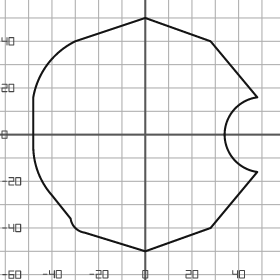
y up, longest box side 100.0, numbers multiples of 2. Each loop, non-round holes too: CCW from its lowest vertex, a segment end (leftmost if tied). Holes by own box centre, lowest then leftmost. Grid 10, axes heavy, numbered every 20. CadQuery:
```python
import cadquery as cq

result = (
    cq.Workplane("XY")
    .moveTo(0.0, -50.0)
    .lineTo(28.0, -40.0)
    .lineTo(48.0, -16.0)
    .threePointArc((34.0, 0.0), (48.0, 16.0))
    .lineTo(28.0, 40.0)
    .lineTo(0.0, 50.0)
    .lineTo(-30.0, 40.0)
    .threePointArc((-42.0, 30.0), (-48.0, 16.0))
    .lineTo(-48.0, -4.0)
    .threePointArc((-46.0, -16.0), (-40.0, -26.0))
    .lineTo(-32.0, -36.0)
    .threePointArc((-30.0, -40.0), (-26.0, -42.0))
    .close()
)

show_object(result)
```